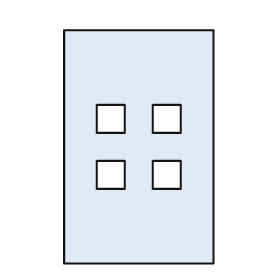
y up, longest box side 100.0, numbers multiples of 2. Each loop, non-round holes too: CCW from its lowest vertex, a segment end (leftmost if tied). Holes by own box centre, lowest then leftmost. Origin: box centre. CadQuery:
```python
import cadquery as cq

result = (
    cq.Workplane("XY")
    .moveTo(-32.0, -50.0)
    .lineTo(32.0, -50.0)
    .lineTo(32.0, 50.0)
    .lineTo(-32.0, 50.0)
    .close()
    .moveTo(-18.0, -18.0)
    .lineTo(-6.0, -18.0)
    .lineTo(-6.0, -6.0)
    .lineTo(-18.0, -6.0)
    .close()
    .moveTo(6.0, -18.0)
    .lineTo(18.0, -18.0)
    .lineTo(18.0, -6.0)
    .lineTo(6.0, -6.0)
    .close()
    .moveTo(-18.0, 6.0)
    .lineTo(-6.0, 6.0)
    .lineTo(-6.0, 18.0)
    .lineTo(-18.0, 18.0)
    .close()
    .moveTo(6.0, 6.0)
    .lineTo(18.0, 6.0)
    .lineTo(18.0, 18.0)
    .lineTo(6.0, 18.0)
    .close()
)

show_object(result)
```